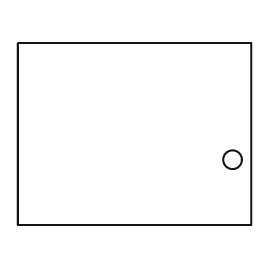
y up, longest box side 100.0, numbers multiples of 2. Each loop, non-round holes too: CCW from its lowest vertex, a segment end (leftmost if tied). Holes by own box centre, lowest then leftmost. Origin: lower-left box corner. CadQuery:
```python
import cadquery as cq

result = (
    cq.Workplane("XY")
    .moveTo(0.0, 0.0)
    .lineTo(100.0, 0.0)
    .lineTo(100.0, 78.0)
    .lineTo(0.0, 78.0)
    .close()
    .moveTo(92.0, 28.0)
    .circle(4.0)
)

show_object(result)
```